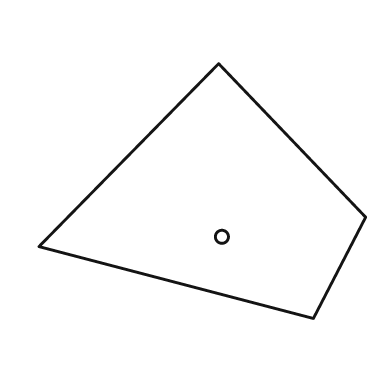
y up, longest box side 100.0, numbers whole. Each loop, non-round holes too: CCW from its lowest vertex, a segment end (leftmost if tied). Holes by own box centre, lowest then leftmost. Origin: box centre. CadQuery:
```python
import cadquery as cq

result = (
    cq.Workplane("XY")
    .moveTo(34.0, -39.0)
    .lineTo(50.0, -8.0)
    .lineTo(5.0, 39.0)
    .lineTo(-50.0, -17.0)
    .close()
    .moveTo(6.0, -14.0)
    .circle(2.0)
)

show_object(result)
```